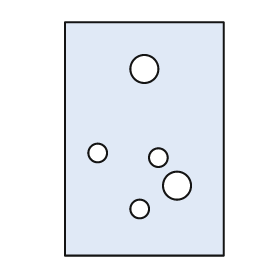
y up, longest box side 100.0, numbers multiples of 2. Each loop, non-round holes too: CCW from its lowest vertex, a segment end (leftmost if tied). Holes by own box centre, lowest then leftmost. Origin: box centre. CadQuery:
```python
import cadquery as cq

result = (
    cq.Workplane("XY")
    .moveTo(-34.0, -50.0)
    .lineTo(34.0, -50.0)
    .lineTo(34.0, 50.0)
    .lineTo(-34.0, 50.0)
    .close()
    .moveTo(-2.0, -30.0)
    .circle(4.0)
    .moveTo(14.0, -20.0)
    .circle(6.0)
    .moveTo(6.0, -8.0)
    .circle(4.0)
    .moveTo(-20.0, -6.0)
    .circle(4.0)
    .moveTo(0.0, 30.0)
    .circle(6.0)
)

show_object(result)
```